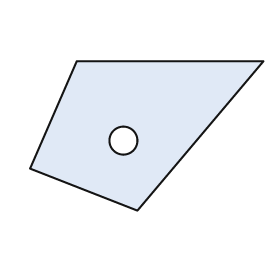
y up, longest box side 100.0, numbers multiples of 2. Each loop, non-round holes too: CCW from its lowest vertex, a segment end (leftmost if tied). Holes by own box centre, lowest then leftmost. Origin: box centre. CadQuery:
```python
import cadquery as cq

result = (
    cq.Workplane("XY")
    .moveTo(-4.0, -32.0)
    .lineTo(50.0, 32.0)
    .lineTo(-30.0, 32.0)
    .lineTo(-50.0, -14.0)
    .close()
    .moveTo(-10.0, -2.0)
    .circle(6.0)
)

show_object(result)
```